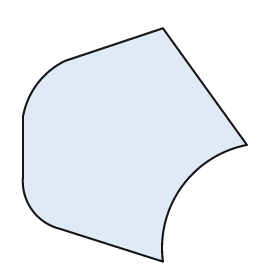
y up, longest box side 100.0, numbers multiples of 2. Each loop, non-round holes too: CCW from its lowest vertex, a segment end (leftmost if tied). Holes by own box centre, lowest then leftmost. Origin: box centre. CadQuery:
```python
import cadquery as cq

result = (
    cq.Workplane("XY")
    .moveTo(12.0, -50.0)
    .threePointArc((20.0, -18.0), (48.0, 0.0))
    .lineTo(12.0, 50.0)
    .lineTo(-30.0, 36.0)
    .threePointArc((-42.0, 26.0), (-48.0, 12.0))
    .lineTo(-48.0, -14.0)
    .threePointArc((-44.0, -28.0), (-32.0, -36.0))
    .close()
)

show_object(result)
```